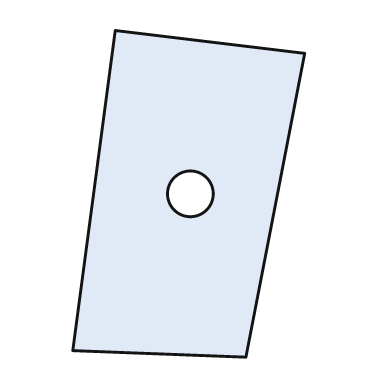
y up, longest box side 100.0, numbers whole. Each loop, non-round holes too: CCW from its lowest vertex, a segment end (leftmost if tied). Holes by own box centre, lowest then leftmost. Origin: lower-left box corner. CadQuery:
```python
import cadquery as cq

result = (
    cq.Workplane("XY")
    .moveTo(53.0, 0.0)
    .lineTo(71.0, 93.0)
    .lineTo(13.0, 100.0)
    .lineTo(0.0, 2.0)
    .close()
    .moveTo(36.0, 50.0)
    .circle(7.0)
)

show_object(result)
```